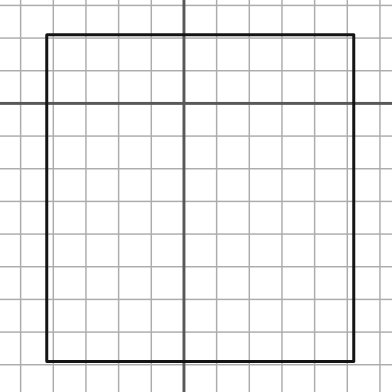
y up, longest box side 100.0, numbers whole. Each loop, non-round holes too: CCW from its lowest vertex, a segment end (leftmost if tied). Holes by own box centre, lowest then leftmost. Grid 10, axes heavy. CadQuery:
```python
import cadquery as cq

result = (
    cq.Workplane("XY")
    .moveTo(-42.0, -79.0)
    .lineTo(52.0, -79.0)
    .lineTo(52.0, 21.0)
    .lineTo(-42.0, 21.0)
    .close()
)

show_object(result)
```